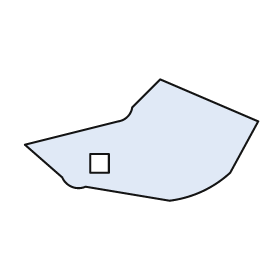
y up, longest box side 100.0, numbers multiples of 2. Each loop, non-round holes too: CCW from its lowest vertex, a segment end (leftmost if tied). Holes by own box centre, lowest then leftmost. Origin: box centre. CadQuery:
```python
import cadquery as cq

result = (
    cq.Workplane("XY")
    .moveTo(12.0, -26.0)
    .threePointArc((26.0, -22.0), (38.0, -14.0))
    .lineTo(50.0, 8.0)
    .lineTo(8.0, 26.0)
    .lineTo(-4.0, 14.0)
    .threePointArc((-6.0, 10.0), (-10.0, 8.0))
    .lineTo(-50.0, -2.0)
    .lineTo(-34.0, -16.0)
    .threePointArc((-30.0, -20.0), (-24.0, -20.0))
    .close()
    .moveTo(-22.0, -14.0)
    .lineTo(-14.0, -14.0)
    .lineTo(-14.0, -6.0)
    .lineTo(-22.0, -6.0)
    .close()
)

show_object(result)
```